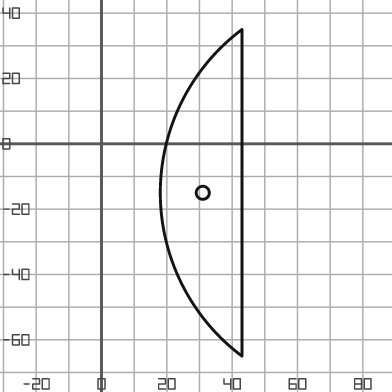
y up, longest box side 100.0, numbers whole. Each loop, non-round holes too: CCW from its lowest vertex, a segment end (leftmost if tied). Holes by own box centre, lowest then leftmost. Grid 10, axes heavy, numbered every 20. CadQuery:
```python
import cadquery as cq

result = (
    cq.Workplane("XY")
    .moveTo(43.0, -65.0)
    .lineTo(43.0, 35.0)
    .threePointArc((18.0, -15.0), (43.0, -65.0))
    .close()
    .moveTo(31.0, -15.0)
    .circle(2.0)
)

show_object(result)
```